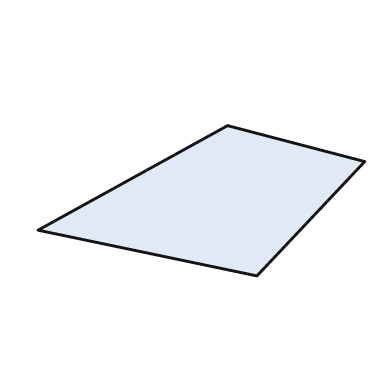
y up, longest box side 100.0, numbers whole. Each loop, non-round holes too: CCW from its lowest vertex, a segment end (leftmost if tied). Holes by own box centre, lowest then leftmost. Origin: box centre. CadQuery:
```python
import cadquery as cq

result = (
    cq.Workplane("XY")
    .moveTo(17.0, -23.0)
    .lineTo(50.0, 12.0)
    .lineTo(8.0, 23.0)
    .lineTo(-50.0, -9.0)
    .close()
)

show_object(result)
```